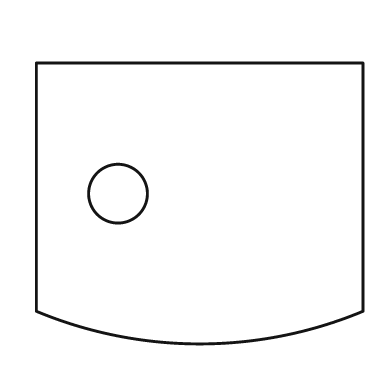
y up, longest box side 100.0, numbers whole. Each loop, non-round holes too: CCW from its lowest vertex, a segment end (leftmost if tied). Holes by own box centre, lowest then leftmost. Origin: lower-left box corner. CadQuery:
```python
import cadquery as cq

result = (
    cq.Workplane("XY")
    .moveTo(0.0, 10.0)
    .threePointArc((50.0, 0.0), (100.0, 10.0))
    .lineTo(100.0, 86.0)
    .lineTo(0.0, 86.0)
    .close()
    .moveTo(25.0, 46.0)
    .circle(9.0)
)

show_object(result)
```